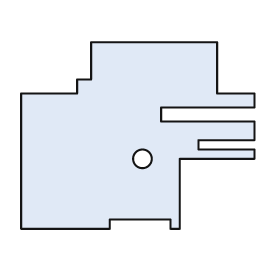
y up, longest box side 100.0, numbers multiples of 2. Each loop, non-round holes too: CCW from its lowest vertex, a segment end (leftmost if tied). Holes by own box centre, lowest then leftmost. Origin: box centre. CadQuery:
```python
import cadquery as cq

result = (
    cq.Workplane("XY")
    .moveTo(-50.0, -40.0)
    .lineTo(-12.0, -40.0)
    .lineTo(-12.0, -36.0)
    .lineTo(14.0, -36.0)
    .lineTo(14.0, -40.0)
    .lineTo(18.0, -40.0)
    .lineTo(18.0, -10.0)
    .lineTo(50.0, -10.0)
    .lineTo(50.0, -6.0)
    .lineTo(26.0, -6.0)
    .lineTo(26.0, -2.0)
    .lineTo(50.0, -2.0)
    .lineTo(50.0, 6.0)
    .lineTo(10.0, 6.0)
    .lineTo(10.0, 12.0)
    .lineTo(50.0, 12.0)
    .lineTo(50.0, 18.0)
    .lineTo(34.0, 18.0)
    .lineTo(34.0, 40.0)
    .lineTo(-20.0, 40.0)
    .lineTo(-20.0, 24.0)
    .lineTo(-26.0, 24.0)
    .lineTo(-26.0, 18.0)
    .lineTo(-50.0, 18.0)
    .close()
    .moveTo(2.0, -10.0)
    .circle(4.0)
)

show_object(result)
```